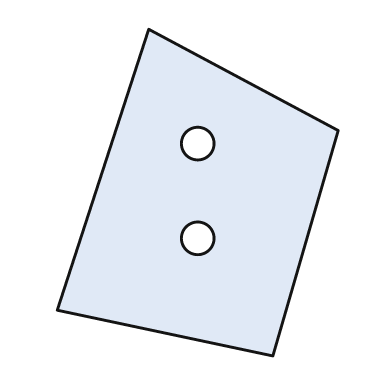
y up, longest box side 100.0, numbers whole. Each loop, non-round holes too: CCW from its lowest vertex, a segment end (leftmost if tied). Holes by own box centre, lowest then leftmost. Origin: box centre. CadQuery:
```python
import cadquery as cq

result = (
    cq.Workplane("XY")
    .moveTo(23.0, -50.0)
    .lineTo(43.0, 19.0)
    .lineTo(-15.0, 50.0)
    .lineTo(-43.0, -36.0)
    .close()
    .moveTo(0.0, -14.0)
    .circle(5.0)
    .moveTo(0.0, 15.0)
    .circle(5.0)
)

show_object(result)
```